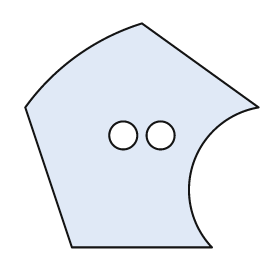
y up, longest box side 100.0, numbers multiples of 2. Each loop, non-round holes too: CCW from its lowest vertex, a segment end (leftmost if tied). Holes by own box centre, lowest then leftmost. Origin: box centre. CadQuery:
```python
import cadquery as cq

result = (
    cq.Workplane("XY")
    .moveTo(-30.0, -48.0)
    .lineTo(30.0, -48.0)
    .threePointArc((22.0, -12.0), (50.0, 12.0))
    .lineTo(0.0, 48.0)
    .threePointArc((-28.0, 34.0), (-50.0, 12.0))
    .close()
    .moveTo(-8.0, 0.0)
    .circle(6.0)
    .moveTo(8.0, 0.0)
    .circle(6.0)
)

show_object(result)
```